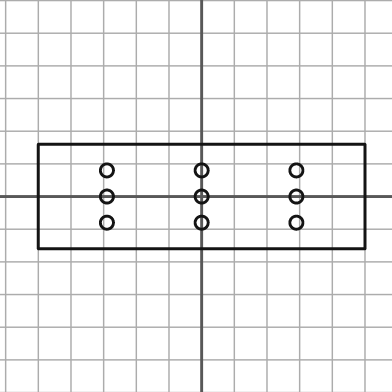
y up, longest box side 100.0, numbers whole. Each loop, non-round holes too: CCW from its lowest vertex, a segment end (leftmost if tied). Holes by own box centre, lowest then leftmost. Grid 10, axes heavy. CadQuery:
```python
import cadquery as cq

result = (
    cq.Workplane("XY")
    .moveTo(-50.0, -16.0)
    .lineTo(50.0, -16.0)
    .lineTo(50.0, 16.0)
    .lineTo(-50.0, 16.0)
    .close()
    .moveTo(-29.0, -8.0)
    .circle(2.0)
    .moveTo(0.0, -8.0)
    .circle(2.0)
    .moveTo(29.0, -8.0)
    .circle(2.0)
    .moveTo(-29.0, 0.0)
    .circle(2.0)
    .moveTo(0.0, 0.0)
    .circle(2.0)
    .moveTo(29.0, 0.0)
    .circle(2.0)
    .moveTo(-29.0, 8.0)
    .circle(2.0)
    .moveTo(0.0, 8.0)
    .circle(2.0)
    .moveTo(29.0, 8.0)
    .circle(2.0)
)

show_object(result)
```